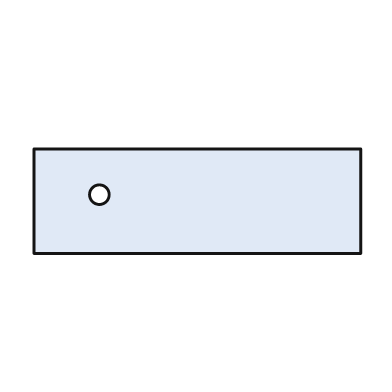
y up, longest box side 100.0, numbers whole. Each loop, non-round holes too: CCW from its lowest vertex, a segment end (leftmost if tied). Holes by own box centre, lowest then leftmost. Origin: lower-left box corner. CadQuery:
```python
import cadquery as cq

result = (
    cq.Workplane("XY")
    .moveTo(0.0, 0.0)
    .lineTo(100.0, 0.0)
    .lineTo(100.0, 32.0)
    .lineTo(0.0, 32.0)
    .close()
    .moveTo(20.0, 18.0)
    .circle(3.0)
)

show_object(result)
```